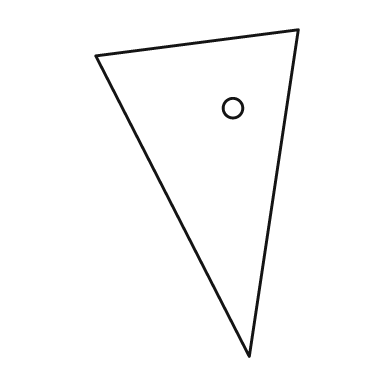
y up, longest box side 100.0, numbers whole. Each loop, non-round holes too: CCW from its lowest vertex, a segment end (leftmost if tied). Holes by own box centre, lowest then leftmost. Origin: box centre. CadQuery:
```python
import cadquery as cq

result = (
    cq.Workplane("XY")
    .moveTo(16.0, -50.0)
    .lineTo(31.0, 50.0)
    .lineTo(-31.0, 42.0)
    .close()
    .moveTo(11.0, 26.0)
    .circle(3.0)
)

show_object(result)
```